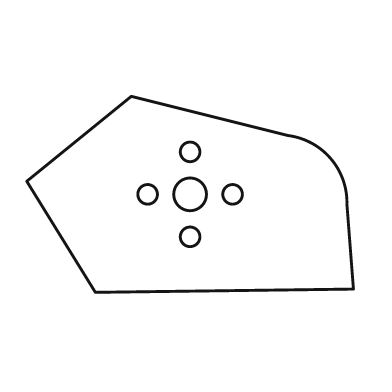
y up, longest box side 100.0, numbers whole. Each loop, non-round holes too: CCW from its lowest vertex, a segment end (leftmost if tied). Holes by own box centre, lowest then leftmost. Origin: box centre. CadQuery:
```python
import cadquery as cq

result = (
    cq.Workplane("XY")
    .moveTo(-29.0, -30.0)
    .lineTo(50.0, -29.0)
    .lineTo(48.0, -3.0)
    .threePointArc((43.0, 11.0), (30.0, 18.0))
    .lineTo(-18.0, 30.0)
    .lineTo(-50.0, 4.0)
    .close()
    .moveTo(0.0, -13.0)
    .circle(3.0)
    .moveTo(-13.0, 0.0)
    .circle(3.0)
    .moveTo(0.0, 0.0)
    .circle(5.0)
    .moveTo(13.0, 0.0)
    .circle(3.0)
    .moveTo(0.0, 13.0)
    .circle(3.0)
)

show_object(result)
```